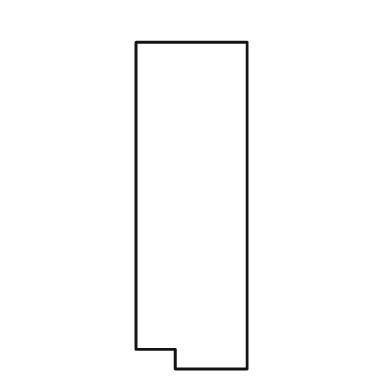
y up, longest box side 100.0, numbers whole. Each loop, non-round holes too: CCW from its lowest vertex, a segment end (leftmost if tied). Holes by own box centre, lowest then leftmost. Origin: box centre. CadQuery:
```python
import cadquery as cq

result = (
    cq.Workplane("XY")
    .moveTo(-5.0, -50.0)
    .lineTo(17.0, -50.0)
    .lineTo(17.0, 50.0)
    .lineTo(-17.0, 50.0)
    .lineTo(-17.0, -44.0)
    .lineTo(-5.0, -44.0)
    .close()
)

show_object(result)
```